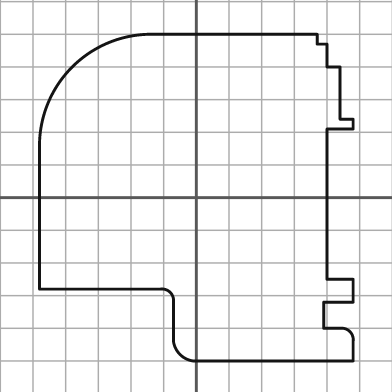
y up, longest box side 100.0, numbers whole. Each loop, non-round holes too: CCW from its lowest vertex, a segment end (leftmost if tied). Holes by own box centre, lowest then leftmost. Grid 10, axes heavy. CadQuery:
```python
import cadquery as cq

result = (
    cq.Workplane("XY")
    .moveTo(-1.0, -50.0)
    .lineTo(48.0, -50.0)
    .lineTo(48.0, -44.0)
    .threePointArc((47.0, -41.0), (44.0, -40.0))
    .lineTo(39.0, -40.0)
    .lineTo(39.0, -32.0)
    .lineTo(48.0, -32.0)
    .lineTo(48.0, -25.0)
    .lineTo(40.0, -25.0)
    .lineTo(40.0, 21.0)
    .lineTo(48.0, 21.0)
    .lineTo(48.0, 24.0)
    .lineTo(44.0, 24.0)
    .lineTo(44.0, 40.0)
    .lineTo(40.0, 40.0)
    .lineTo(40.0, 47.0)
    .lineTo(37.0, 47.0)
    .lineTo(37.0, 50.0)
    .lineTo(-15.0, 50.0)
    .threePointArc((-38.0, 40.0), (-48.0, 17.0))
    .lineTo(-48.0, -28.0)
    .lineTo(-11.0, -28.0)
    .threePointArc((-8.0, -29.0), (-7.0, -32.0))
    .lineTo(-7.0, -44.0)
    .threePointArc((-5.0, -48.0), (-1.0, -50.0))
    .close()
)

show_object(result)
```